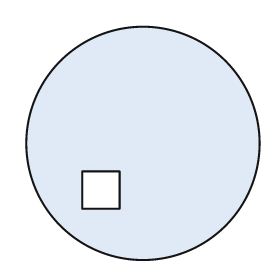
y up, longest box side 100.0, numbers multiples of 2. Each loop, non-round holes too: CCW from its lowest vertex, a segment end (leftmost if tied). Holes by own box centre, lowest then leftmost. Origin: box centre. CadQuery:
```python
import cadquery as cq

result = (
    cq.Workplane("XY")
    .moveTo(0.0, 0.0)
    .circle(50.0)
    .moveTo(-26.0, -28.0)
    .lineTo(-10.0, -28.0)
    .lineTo(-10.0, -12.0)
    .lineTo(-26.0, -12.0)
    .close()
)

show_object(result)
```